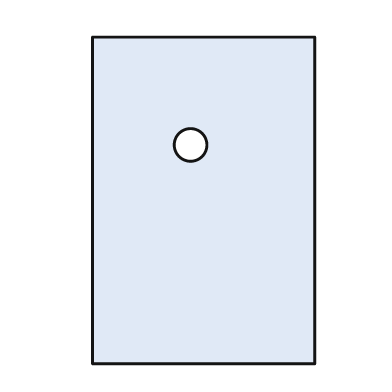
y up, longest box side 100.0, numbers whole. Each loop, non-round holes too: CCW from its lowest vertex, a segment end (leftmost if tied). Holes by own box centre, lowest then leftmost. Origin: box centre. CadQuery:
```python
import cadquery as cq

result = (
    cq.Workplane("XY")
    .moveTo(-34.0, -50.0)
    .lineTo(34.0, -50.0)
    .lineTo(34.0, 50.0)
    .lineTo(-34.0, 50.0)
    .close()
    .moveTo(-4.0, 17.0)
    .circle(5.0)
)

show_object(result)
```